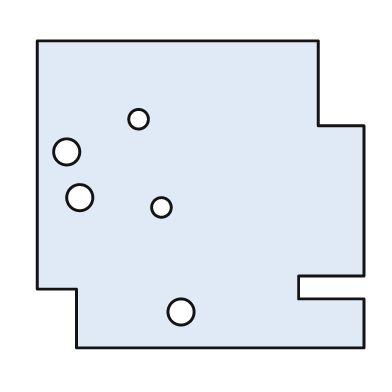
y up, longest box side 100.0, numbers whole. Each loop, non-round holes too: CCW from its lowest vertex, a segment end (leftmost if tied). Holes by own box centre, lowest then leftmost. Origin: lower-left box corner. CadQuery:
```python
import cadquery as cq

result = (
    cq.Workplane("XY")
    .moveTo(12.0, 0.0)
    .lineTo(100.0, 0.0)
    .lineTo(100.0, 15.0)
    .lineTo(80.0, 15.0)
    .lineTo(80.0, 22.0)
    .lineTo(100.0, 22.0)
    .lineTo(100.0, 68.0)
    .lineTo(86.0, 68.0)
    .lineTo(86.0, 94.0)
    .lineTo(0.0, 94.0)
    .lineTo(0.0, 18.0)
    .lineTo(12.0, 18.0)
    .close()
    .moveTo(44.0, 11.0)
    .circle(4.0)
    .moveTo(38.0, 43.0)
    .circle(3.0)
    .moveTo(13.0, 46.0)
    .circle(4.0)
    .moveTo(9.0, 60.0)
    .circle(4.0)
    .moveTo(31.0, 70.0)
    .circle(3.0)
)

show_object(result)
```